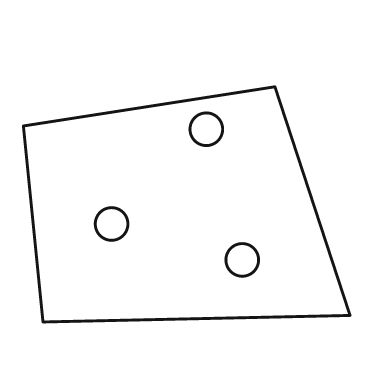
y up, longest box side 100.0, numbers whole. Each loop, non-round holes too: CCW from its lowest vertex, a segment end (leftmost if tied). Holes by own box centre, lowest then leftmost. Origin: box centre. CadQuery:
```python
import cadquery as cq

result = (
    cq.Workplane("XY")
    .moveTo(-44.0, -36.0)
    .lineTo(50.0, -34.0)
    .lineTo(27.0, 36.0)
    .lineTo(-50.0, 24.0)
    .close()
    .moveTo(17.0, -17.0)
    .circle(5.0)
    .moveTo(-23.0, -6.0)
    .circle(5.0)
    .moveTo(6.0, 23.0)
    .circle(5.0)
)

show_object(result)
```